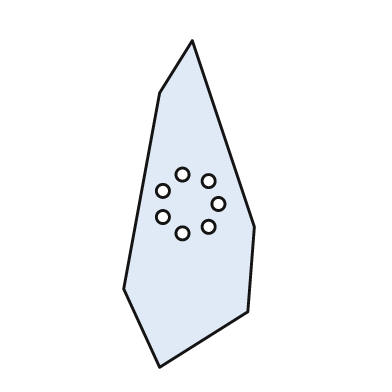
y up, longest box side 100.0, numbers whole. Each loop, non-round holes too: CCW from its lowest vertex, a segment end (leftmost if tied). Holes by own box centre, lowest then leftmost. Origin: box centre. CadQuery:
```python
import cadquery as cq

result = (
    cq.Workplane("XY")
    .moveTo(-9.0, -50.0)
    .lineTo(18.0, -33.0)
    .lineTo(20.0, -7.0)
    .lineTo(1.0, 50.0)
    .lineTo(-9.0, 34.0)
    .lineTo(-20.0, -26.0)
    .close()
    .moveTo(-2.0, -9.0)
    .circle(2.0)
    .moveTo(6.0, -7.0)
    .circle(2.0)
    .moveTo(-8.0, -4.0)
    .circle(2.0)
    .moveTo(9.0, 0.0)
    .circle(2.0)
    .moveTo(-8.0, 4.0)
    .circle(2.0)
    .moveTo(6.0, 7.0)
    .circle(2.0)
    .moveTo(-2.0, 9.0)
    .circle(2.0)
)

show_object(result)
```